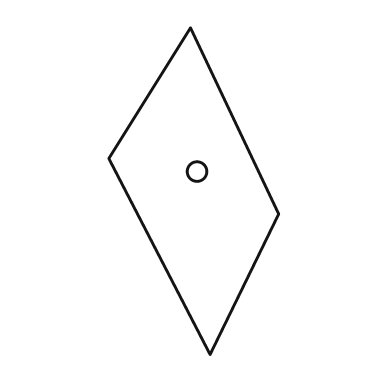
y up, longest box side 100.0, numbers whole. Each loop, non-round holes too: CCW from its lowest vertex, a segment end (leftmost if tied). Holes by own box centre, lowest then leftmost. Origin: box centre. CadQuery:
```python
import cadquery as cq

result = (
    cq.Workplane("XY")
    .moveTo(5.0, -50.0)
    .lineTo(26.0, -7.0)
    .lineTo(-1.0, 50.0)
    .lineTo(-26.0, 10.0)
    .close()
    .moveTo(1.0, 6.0)
    .circle(3.0)
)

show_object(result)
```